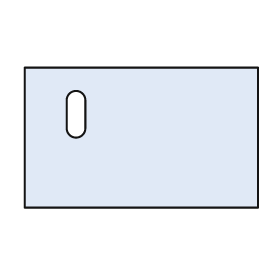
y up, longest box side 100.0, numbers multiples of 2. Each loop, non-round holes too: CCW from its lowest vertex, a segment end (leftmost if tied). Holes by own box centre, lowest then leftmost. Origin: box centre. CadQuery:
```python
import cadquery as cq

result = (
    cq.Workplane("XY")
    .moveTo(-50.0, -30.0)
    .lineTo(50.0, -30.0)
    .lineTo(50.0, 30.0)
    .lineTo(-50.0, 30.0)
    .close()
    .moveTo(-32.0, 4.0)
    .threePointArc((-28.0, 0.0), (-24.0, 4.0))
    .lineTo(-24.0, 16.0)
    .threePointArc((-28.0, 20.0), (-32.0, 16.0))
    .close()
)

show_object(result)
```